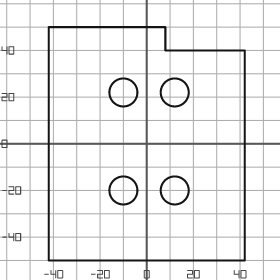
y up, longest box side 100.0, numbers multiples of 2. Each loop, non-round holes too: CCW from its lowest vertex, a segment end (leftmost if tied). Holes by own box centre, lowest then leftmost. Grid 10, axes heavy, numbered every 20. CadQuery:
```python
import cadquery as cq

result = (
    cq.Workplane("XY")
    .moveTo(-42.0, -50.0)
    .lineTo(42.0, -50.0)
    .lineTo(42.0, 40.0)
    .lineTo(8.0, 40.0)
    .lineTo(8.0, 50.0)
    .lineTo(-42.0, 50.0)
    .close()
    .moveTo(-10.0, -20.0)
    .circle(6.0)
    .moveTo(12.0, -20.0)
    .circle(6.0)
    .moveTo(-10.0, 22.0)
    .circle(6.0)
    .moveTo(12.0, 22.0)
    .circle(6.0)
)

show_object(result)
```